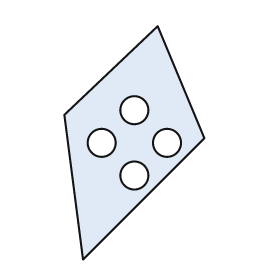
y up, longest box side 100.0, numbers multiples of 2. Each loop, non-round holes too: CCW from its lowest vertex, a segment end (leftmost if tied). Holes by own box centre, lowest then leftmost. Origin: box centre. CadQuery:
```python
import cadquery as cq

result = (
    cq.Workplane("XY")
    .moveTo(-22.0, -50.0)
    .lineTo(30.0, 2.0)
    .lineTo(10.0, 50.0)
    .lineTo(-30.0, 12.0)
    .close()
    .moveTo(0.0, -14.0)
    .circle(6.0)
    .moveTo(-14.0, 0.0)
    .circle(6.0)
    .moveTo(14.0, 0.0)
    .circle(6.0)
    .moveTo(0.0, 14.0)
    .circle(6.0)
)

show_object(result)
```